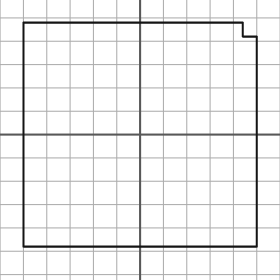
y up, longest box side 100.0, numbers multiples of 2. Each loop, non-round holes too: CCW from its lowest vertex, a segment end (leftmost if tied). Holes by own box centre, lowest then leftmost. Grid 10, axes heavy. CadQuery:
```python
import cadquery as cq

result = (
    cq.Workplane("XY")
    .moveTo(-50.0, -48.0)
    .lineTo(50.0, -48.0)
    .lineTo(50.0, 42.0)
    .lineTo(44.0, 42.0)
    .lineTo(44.0, 48.0)
    .lineTo(-50.0, 48.0)
    .close()
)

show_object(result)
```